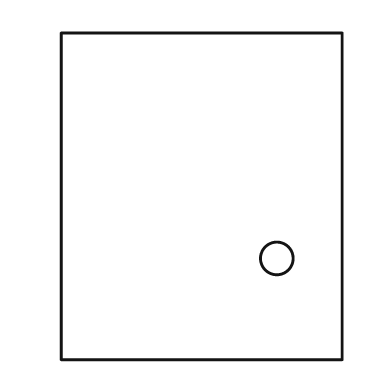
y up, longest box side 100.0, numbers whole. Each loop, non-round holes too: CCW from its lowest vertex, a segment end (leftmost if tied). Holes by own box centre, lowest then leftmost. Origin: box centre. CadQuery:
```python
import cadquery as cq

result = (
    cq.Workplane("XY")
    .moveTo(-43.0, -50.0)
    .lineTo(43.0, -50.0)
    .lineTo(43.0, 50.0)
    .lineTo(-43.0, 50.0)
    .close()
    .moveTo(23.0, -19.0)
    .circle(5.0)
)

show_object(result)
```